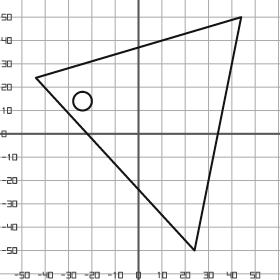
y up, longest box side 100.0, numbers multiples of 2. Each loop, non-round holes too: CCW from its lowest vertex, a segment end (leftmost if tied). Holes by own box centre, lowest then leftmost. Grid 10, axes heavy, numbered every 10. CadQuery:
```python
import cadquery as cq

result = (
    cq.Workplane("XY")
    .moveTo(24.0, -50.0)
    .lineTo(44.0, 50.0)
    .lineTo(-44.0, 24.0)
    .close()
    .moveTo(-24.0, 14.0)
    .circle(4.0)
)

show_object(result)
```